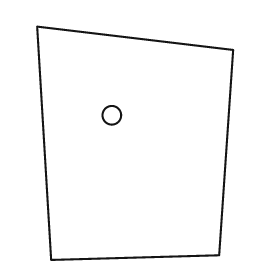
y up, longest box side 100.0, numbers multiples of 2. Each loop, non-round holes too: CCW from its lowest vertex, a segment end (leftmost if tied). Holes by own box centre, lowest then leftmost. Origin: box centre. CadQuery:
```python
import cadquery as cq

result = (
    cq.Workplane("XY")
    .moveTo(-36.0, -50.0)
    .lineTo(36.0, -48.0)
    .lineTo(42.0, 40.0)
    .lineTo(-42.0, 50.0)
    .close()
    .moveTo(-10.0, 12.0)
    .circle(4.0)
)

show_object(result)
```